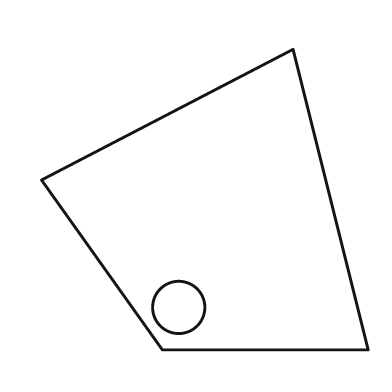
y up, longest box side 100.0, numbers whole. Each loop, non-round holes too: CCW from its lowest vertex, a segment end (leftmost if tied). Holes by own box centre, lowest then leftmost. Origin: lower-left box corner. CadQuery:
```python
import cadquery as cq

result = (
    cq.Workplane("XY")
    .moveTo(37.0, 0.0)
    .lineTo(100.0, 0.0)
    .lineTo(77.0, 92.0)
    .lineTo(0.0, 52.0)
    .close()
    .moveTo(42.0, 13.0)
    .circle(8.0)
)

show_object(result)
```